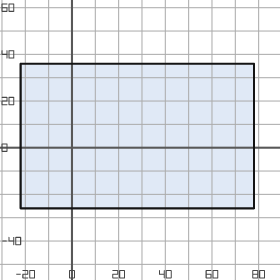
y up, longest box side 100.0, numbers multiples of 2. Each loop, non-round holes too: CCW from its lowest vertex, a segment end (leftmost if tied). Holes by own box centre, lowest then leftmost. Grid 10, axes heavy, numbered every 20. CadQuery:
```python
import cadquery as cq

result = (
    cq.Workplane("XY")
    .moveTo(-22.0, -26.0)
    .lineTo(78.0, -26.0)
    .lineTo(78.0, 36.0)
    .lineTo(-22.0, 36.0)
    .close()
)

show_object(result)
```